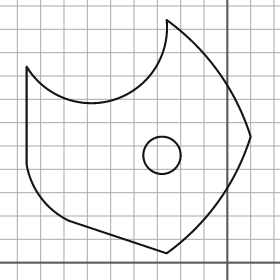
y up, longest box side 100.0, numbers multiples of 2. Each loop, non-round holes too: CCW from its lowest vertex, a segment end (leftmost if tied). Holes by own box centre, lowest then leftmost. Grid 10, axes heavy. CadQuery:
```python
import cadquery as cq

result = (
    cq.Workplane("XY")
    .moveTo(-26.0, 4.0)
    .threePointArc((-4.0, 26.0), (10.0, 54.0))
    .threePointArc((-4.0, 82.0), (-26.0, 104.0))
    .threePointArc((-48.0, 70.0), (-86.0, 84.0))
    .lineTo(-86.0, 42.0)
    .threePointArc((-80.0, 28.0), (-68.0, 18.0))
    .close()
    .moveTo(-28.0, 46.0)
    .circle(8.0)
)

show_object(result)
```